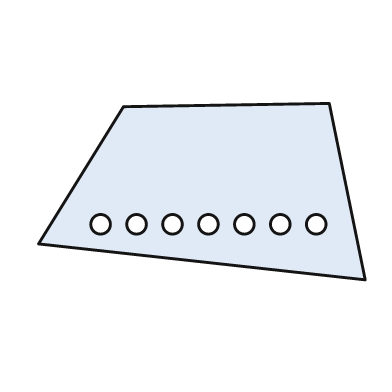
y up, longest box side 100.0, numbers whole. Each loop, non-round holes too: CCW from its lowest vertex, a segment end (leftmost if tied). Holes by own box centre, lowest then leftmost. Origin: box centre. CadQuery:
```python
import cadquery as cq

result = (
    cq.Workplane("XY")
    .moveTo(50.0, -27.0)
    .lineTo(39.0, 27.0)
    .lineTo(-24.0, 26.0)
    .lineTo(-50.0, -16.0)
    .close()
    .moveTo(-31.0, -10.0)
    .circle(3.0)
    .moveTo(-20.0, -10.0)
    .circle(3.0)
    .moveTo(-9.0, -10.0)
    .circle(3.0)
    .moveTo(2.0, -10.0)
    .circle(3.0)
    .moveTo(13.0, -10.0)
    .circle(3.0)
    .moveTo(24.0, -10.0)
    .circle(3.0)
    .moveTo(35.0, -10.0)
    .circle(3.0)
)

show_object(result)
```